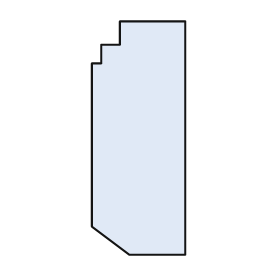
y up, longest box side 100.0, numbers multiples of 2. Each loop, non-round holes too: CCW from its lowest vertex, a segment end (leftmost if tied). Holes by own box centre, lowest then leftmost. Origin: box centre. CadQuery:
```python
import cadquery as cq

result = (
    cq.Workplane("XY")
    .moveTo(-4.0, -50.0)
    .lineTo(20.0, -50.0)
    .lineTo(20.0, 50.0)
    .lineTo(-8.0, 50.0)
    .lineTo(-8.0, 40.0)
    .lineTo(-16.0, 40.0)
    .lineTo(-16.0, 32.0)
    .lineTo(-20.0, 32.0)
    .lineTo(-20.0, -38.0)
    .close()
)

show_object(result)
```